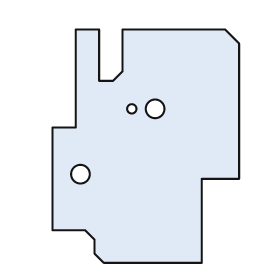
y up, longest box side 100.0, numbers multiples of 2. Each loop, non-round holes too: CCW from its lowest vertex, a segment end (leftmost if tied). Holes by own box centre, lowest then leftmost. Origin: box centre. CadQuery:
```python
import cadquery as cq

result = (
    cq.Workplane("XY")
    .moveTo(-18.0, -50.0)
    .lineTo(24.0, -50.0)
    .lineTo(24.0, -14.0)
    .lineTo(40.0, -14.0)
    .lineTo(40.0, 44.0)
    .lineTo(34.0, 50.0)
    .lineTo(-10.0, 50.0)
    .lineTo(-10.0, 32.0)
    .lineTo(-14.0, 28.0)
    .lineTo(-20.0, 28.0)
    .lineTo(-20.0, 50.0)
    .lineTo(-30.0, 50.0)
    .lineTo(-30.0, 8.0)
    .lineTo(-40.0, 8.0)
    .lineTo(-40.0, -36.0)
    .lineTo(-26.0, -36.0)
    .lineTo(-22.0, -40.0)
    .lineTo(-22.0, -46.0)
    .close()
    .moveTo(-28.0, -12.0)
    .circle(4.0)
    .moveTo(-6.0, 16.0)
    .circle(2.0)
    .moveTo(4.0, 16.0)
    .circle(4.0)
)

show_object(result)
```